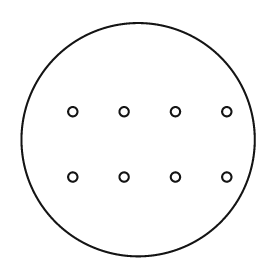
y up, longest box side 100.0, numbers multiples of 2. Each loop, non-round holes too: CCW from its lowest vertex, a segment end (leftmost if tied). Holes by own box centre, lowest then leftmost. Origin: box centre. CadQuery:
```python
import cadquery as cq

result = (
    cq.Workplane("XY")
    .moveTo(0.0, 0.0)
    .circle(50.0)
    .moveTo(-28.0, -16.0)
    .circle(2.0)
    .moveTo(-6.0, -16.0)
    .circle(2.0)
    .moveTo(16.0, -16.0)
    .circle(2.0)
    .moveTo(38.0, -16.0)
    .circle(2.0)
    .moveTo(-28.0, 12.0)
    .circle(2.0)
    .moveTo(-6.0, 12.0)
    .circle(2.0)
    .moveTo(16.0, 12.0)
    .circle(2.0)
    .moveTo(38.0, 12.0)
    .circle(2.0)
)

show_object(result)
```